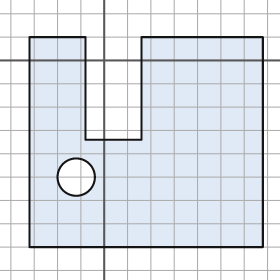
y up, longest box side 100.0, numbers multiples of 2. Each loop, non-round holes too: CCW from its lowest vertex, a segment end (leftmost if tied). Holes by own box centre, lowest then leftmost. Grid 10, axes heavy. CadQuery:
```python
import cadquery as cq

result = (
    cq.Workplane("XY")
    .moveTo(-32.0, -80.0)
    .lineTo(68.0, -80.0)
    .lineTo(68.0, 10.0)
    .lineTo(16.0, 10.0)
    .lineTo(16.0, -34.0)
    .lineTo(-8.0, -34.0)
    .lineTo(-8.0, 10.0)
    .lineTo(-32.0, 10.0)
    .close()
    .moveTo(-12.0, -50.0)
    .circle(8.0)
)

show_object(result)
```